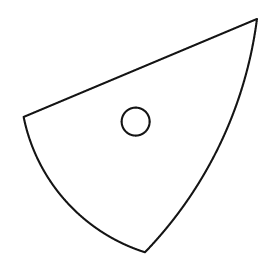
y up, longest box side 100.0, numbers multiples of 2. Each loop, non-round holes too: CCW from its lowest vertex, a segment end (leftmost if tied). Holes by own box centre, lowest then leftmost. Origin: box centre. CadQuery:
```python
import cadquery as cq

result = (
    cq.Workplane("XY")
    .moveTo(2.0, -50.0)
    .threePointArc((34.0, -4.0), (50.0, 50.0))
    .lineTo(-50.0, 8.0)
    .threePointArc((-32.0, -28.0), (2.0, -50.0))
    .close()
    .moveTo(-2.0, 6.0)
    .circle(6.0)
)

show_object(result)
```